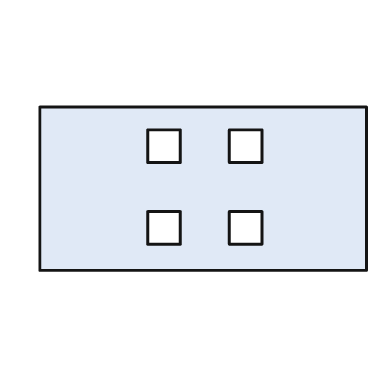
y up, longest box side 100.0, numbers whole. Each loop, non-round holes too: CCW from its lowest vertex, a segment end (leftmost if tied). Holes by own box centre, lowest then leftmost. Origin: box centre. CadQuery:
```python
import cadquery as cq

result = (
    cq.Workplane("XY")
    .moveTo(-50.0, -25.0)
    .lineTo(50.0, -25.0)
    .lineTo(50.0, 25.0)
    .lineTo(-50.0, 25.0)
    .close()
    .moveTo(-17.0, -17.0)
    .lineTo(-7.0, -17.0)
    .lineTo(-7.0, -7.0)
    .lineTo(-17.0, -7.0)
    .close()
    .moveTo(8.0, -17.0)
    .lineTo(18.0, -17.0)
    .lineTo(18.0, -7.0)
    .lineTo(8.0, -7.0)
    .close()
    .moveTo(-17.0, 8.0)
    .lineTo(-7.0, 8.0)
    .lineTo(-7.0, 18.0)
    .lineTo(-17.0, 18.0)
    .close()
    .moveTo(8.0, 8.0)
    .lineTo(18.0, 8.0)
    .lineTo(18.0, 18.0)
    .lineTo(8.0, 18.0)
    .close()
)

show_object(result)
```